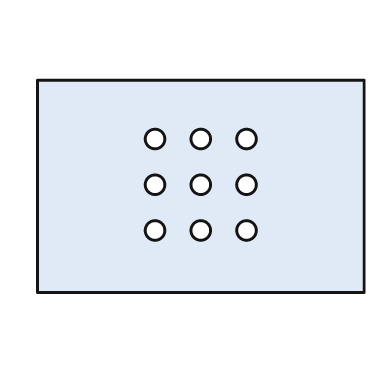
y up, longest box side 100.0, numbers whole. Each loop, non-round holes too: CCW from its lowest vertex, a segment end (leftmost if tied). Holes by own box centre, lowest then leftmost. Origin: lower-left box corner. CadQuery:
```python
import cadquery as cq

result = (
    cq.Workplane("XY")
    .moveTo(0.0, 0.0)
    .lineTo(100.0, 0.0)
    .lineTo(100.0, 65.0)
    .lineTo(0.0, 65.0)
    .close()
    .moveTo(36.0, 19.0)
    .circle(3.0)
    .moveTo(50.0, 19.0)
    .circle(3.0)
    .moveTo(64.0, 19.0)
    .circle(3.0)
    .moveTo(36.0, 33.0)
    .circle(3.0)
    .moveTo(50.0, 33.0)
    .circle(3.0)
    .moveTo(64.0, 33.0)
    .circle(3.0)
    .moveTo(36.0, 47.0)
    .circle(3.0)
    .moveTo(50.0, 47.0)
    .circle(3.0)
    .moveTo(64.0, 47.0)
    .circle(3.0)
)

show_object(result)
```